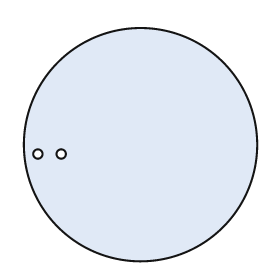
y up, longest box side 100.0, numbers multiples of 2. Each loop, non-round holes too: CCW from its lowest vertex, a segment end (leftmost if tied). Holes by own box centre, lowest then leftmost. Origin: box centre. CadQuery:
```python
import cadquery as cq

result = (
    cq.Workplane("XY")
    .moveTo(0.0, 0.0)
    .circle(50.0)
    .moveTo(-44.0, -4.0)
    .circle(2.0)
    .moveTo(-34.0, -4.0)
    .circle(2.0)
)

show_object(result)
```